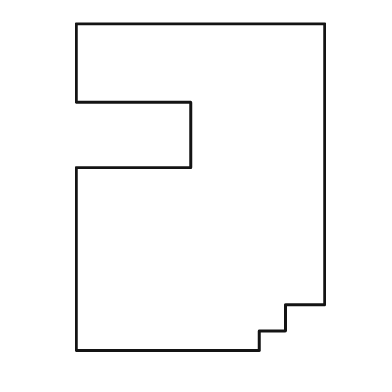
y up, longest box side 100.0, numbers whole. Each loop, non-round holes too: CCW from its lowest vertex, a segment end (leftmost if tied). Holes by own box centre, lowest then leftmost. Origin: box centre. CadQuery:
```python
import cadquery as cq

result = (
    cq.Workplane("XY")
    .moveTo(-38.0, -50.0)
    .lineTo(18.0, -50.0)
    .lineTo(18.0, -44.0)
    .lineTo(26.0, -44.0)
    .lineTo(26.0, -36.0)
    .lineTo(38.0, -36.0)
    .lineTo(38.0, 50.0)
    .lineTo(-38.0, 50.0)
    .lineTo(-38.0, 26.0)
    .lineTo(-3.0, 26.0)
    .lineTo(-3.0, 6.0)
    .lineTo(-38.0, 6.0)
    .close()
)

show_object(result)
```